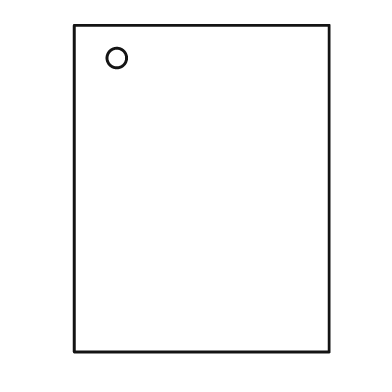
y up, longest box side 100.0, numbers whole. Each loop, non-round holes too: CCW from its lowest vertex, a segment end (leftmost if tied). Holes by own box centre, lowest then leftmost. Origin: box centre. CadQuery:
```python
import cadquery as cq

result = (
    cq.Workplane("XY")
    .moveTo(-39.0, -50.0)
    .lineTo(39.0, -50.0)
    .lineTo(39.0, 50.0)
    .lineTo(-39.0, 50.0)
    .close()
    .moveTo(-26.0, 40.0)
    .circle(3.0)
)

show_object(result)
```